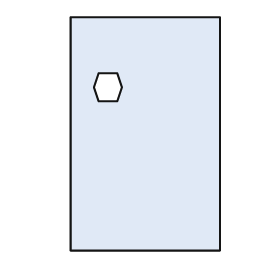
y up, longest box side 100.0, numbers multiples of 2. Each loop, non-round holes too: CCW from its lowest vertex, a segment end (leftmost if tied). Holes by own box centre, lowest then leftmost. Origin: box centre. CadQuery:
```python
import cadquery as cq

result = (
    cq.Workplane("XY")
    .moveTo(-32.0, -50.0)
    .lineTo(32.0, -50.0)
    .lineTo(32.0, 50.0)
    .lineTo(-32.0, 50.0)
    .close()
    .moveTo(-20.0, 14.0)
    .lineTo(-12.0, 14.0)
    .lineTo(-10.0, 20.0)
    .lineTo(-12.0, 26.0)
    .lineTo(-20.0, 26.0)
    .lineTo(-22.0, 20.0)
    .close()
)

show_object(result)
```